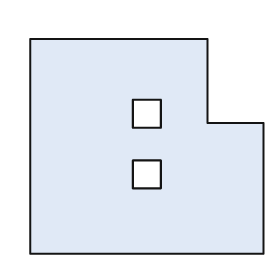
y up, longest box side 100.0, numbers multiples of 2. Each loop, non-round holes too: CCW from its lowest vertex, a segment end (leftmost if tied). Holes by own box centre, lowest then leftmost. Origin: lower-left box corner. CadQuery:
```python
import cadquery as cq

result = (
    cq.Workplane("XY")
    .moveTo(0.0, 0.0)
    .lineTo(100.0, 0.0)
    .lineTo(100.0, 56.0)
    .lineTo(76.0, 56.0)
    .lineTo(76.0, 92.0)
    .lineTo(0.0, 92.0)
    .close()
    .moveTo(44.0, 28.0)
    .lineTo(56.0, 28.0)
    .lineTo(56.0, 40.0)
    .lineTo(44.0, 40.0)
    .close()
    .moveTo(44.0, 54.0)
    .lineTo(56.0, 54.0)
    .lineTo(56.0, 66.0)
    .lineTo(44.0, 66.0)
    .close()
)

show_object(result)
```